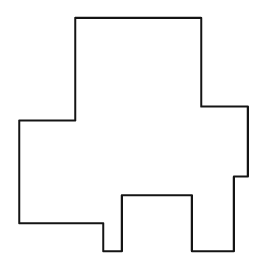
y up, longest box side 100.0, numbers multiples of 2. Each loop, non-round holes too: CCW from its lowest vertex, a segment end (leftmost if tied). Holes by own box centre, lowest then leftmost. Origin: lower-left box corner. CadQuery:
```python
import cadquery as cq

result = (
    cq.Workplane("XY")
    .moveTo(36.0, 0.0)
    .lineTo(44.0, 0.0)
    .lineTo(44.0, 24.0)
    .lineTo(74.0, 24.0)
    .lineTo(74.0, 0.0)
    .lineTo(92.0, 0.0)
    .lineTo(92.0, 32.0)
    .lineTo(98.0, 32.0)
    .lineTo(98.0, 62.0)
    .lineTo(78.0, 62.0)
    .lineTo(78.0, 100.0)
    .lineTo(24.0, 100.0)
    .lineTo(24.0, 56.0)
    .lineTo(0.0, 56.0)
    .lineTo(0.0, 12.0)
    .lineTo(36.0, 12.0)
    .close()
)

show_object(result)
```